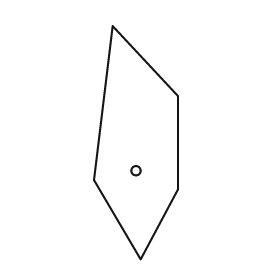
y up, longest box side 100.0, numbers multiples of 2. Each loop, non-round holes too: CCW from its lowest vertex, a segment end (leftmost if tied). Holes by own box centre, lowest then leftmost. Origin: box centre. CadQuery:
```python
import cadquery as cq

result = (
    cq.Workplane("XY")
    .moveTo(2.0, -50.0)
    .lineTo(18.0, -20.0)
    .lineTo(18.0, 20.0)
    .lineTo(-10.0, 50.0)
    .lineTo(-18.0, -16.0)
    .close()
    .moveTo(0.0, -12.0)
    .circle(2.0)
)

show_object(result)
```